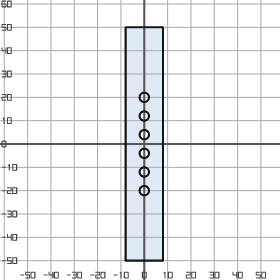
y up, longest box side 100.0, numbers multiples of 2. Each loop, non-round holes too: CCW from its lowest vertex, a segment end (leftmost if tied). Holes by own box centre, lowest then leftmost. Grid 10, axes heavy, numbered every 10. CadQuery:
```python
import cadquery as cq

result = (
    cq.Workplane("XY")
    .moveTo(-8.0, -50.0)
    .lineTo(8.0, -50.0)
    .lineTo(8.0, 50.0)
    .lineTo(-8.0, 50.0)
    .close()
    .moveTo(0.0, -20.0)
    .circle(2.0)
    .moveTo(0.0, -12.0)
    .circle(2.0)
    .moveTo(0.0, -4.0)
    .circle(2.0)
    .moveTo(0.0, 4.0)
    .circle(2.0)
    .moveTo(0.0, 12.0)
    .circle(2.0)
    .moveTo(0.0, 20.0)
    .circle(2.0)
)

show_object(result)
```